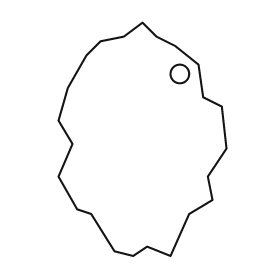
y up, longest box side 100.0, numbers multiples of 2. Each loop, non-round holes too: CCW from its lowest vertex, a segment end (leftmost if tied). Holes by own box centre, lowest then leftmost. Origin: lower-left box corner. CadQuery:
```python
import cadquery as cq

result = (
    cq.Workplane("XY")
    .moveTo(32.0, 0.0)
    .lineTo(38.0, 4.0)
    .lineTo(48.0, 0.0)
    .lineTo(56.0, 18.0)
    .lineTo(66.0, 24.0)
    .lineTo(64.0, 34.0)
    .lineTo(72.0, 46.0)
    .lineTo(70.0, 64.0)
    .lineTo(62.0, 68.0)
    .lineTo(60.0, 82.0)
    .lineTo(50.0, 90.0)
    .lineTo(42.0, 94.0)
    .lineTo(36.0, 100.0)
    .lineTo(28.0, 94.0)
    .lineTo(18.0, 92.0)
    .lineTo(12.0, 86.0)
    .lineTo(4.0, 72.0)
    .lineTo(0.0, 58.0)
    .lineTo(6.0, 48.0)
    .lineTo(0.0, 34.0)
    .lineTo(8.0, 20.0)
    .lineTo(14.0, 18.0)
    .lineTo(24.0, 2.0)
    .close()
    .moveTo(52.0, 78.0)
    .circle(4.0)
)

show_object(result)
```